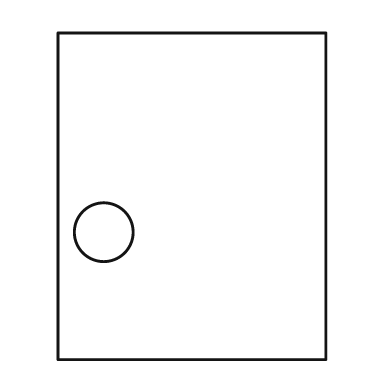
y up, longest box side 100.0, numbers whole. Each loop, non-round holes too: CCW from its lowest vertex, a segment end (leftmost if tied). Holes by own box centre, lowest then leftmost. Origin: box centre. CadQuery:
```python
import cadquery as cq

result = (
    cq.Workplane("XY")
    .moveTo(-41.0, -50.0)
    .lineTo(41.0, -50.0)
    .lineTo(41.0, 50.0)
    .lineTo(-41.0, 50.0)
    .close()
    .moveTo(-27.0, -11.0)
    .circle(9.0)
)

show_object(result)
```